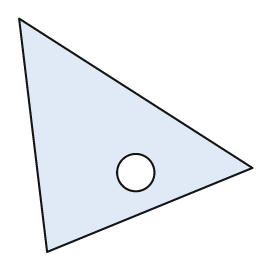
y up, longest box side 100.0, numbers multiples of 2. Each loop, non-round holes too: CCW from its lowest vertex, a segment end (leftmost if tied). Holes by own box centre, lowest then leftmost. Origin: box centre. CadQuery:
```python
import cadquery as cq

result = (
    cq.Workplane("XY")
    .moveTo(-38.0, -50.0)
    .lineTo(50.0, -14.0)
    .lineTo(-50.0, 50.0)
    .close()
    .moveTo(0.0, -16.0)
    .circle(8.0)
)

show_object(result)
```